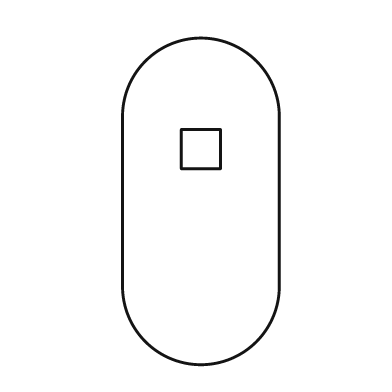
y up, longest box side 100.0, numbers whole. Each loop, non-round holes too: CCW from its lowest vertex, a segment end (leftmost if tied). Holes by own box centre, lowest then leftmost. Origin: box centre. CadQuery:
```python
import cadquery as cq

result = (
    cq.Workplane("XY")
    .moveTo(-24.0, -26.0)
    .threePointArc((0.0, -50.0), (24.0, -26.0))
    .lineTo(24.0, 26.0)
    .threePointArc((0.0, 50.0), (-24.0, 26.0))
    .close()
    .moveTo(-6.0, 10.0)
    .lineTo(6.0, 10.0)
    .lineTo(6.0, 22.0)
    .lineTo(-6.0, 22.0)
    .close()
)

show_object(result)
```